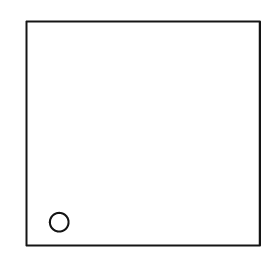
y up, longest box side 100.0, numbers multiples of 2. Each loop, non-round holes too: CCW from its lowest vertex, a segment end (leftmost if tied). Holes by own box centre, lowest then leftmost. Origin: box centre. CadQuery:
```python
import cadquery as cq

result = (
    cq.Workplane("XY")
    .moveTo(-50.0, -48.0)
    .lineTo(50.0, -48.0)
    .lineTo(50.0, 48.0)
    .lineTo(-50.0, 48.0)
    .close()
    .moveTo(-36.0, -38.0)
    .circle(4.0)
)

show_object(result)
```